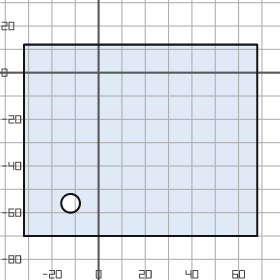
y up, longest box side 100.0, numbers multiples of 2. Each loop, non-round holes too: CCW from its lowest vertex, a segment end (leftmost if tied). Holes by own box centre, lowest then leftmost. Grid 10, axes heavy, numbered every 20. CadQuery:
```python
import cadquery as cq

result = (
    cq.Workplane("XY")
    .moveTo(-32.0, -70.0)
    .lineTo(68.0, -70.0)
    .lineTo(68.0, 12.0)
    .lineTo(-32.0, 12.0)
    .close()
    .moveTo(-12.0, -56.0)
    .circle(4.0)
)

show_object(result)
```